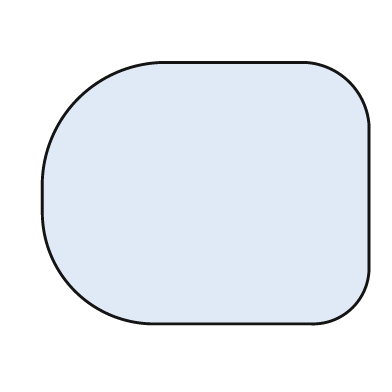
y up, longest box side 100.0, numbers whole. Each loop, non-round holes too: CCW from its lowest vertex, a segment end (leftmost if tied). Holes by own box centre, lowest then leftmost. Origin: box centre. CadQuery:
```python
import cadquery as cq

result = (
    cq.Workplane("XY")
    .moveTo(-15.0, -40.0)
    .lineTo(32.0, -40.0)
    .threePointArc((45.0, -35.0), (50.0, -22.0))
    .lineTo(50.0, 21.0)
    .threePointArc((44.0, 34.0), (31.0, 40.0))
    .lineTo(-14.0, 40.0)
    .threePointArc((-39.0, 29.0), (-50.0, 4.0))
    .lineTo(-50.0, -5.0)
    .threePointArc((-40.0, -30.0), (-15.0, -40.0))
    .close()
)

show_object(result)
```